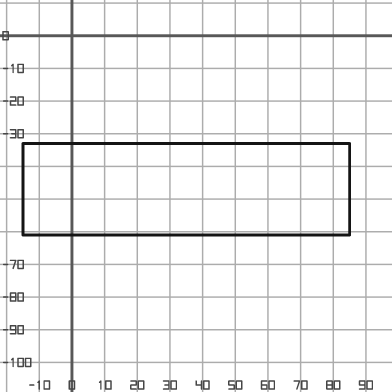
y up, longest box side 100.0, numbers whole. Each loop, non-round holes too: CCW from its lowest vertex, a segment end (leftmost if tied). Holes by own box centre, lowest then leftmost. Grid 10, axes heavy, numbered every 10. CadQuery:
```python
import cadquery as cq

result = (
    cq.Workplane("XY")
    .moveTo(-15.0, -61.0)
    .lineTo(85.0, -61.0)
    .lineTo(85.0, -33.0)
    .lineTo(-15.0, -33.0)
    .close()
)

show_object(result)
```